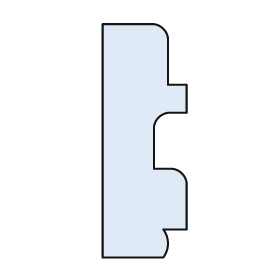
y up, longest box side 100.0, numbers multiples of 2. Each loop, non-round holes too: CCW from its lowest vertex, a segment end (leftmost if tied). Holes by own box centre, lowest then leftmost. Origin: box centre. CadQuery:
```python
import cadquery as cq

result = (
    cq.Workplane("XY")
    .moveTo(-18.0, -50.0)
    .lineTo(8.0, -50.0)
    .threePointArc((10.0, -44.0), (8.0, -38.0))
    .lineTo(18.0, -38.0)
    .lineTo(18.0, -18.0)
    .threePointArc((16.0, -14.0), (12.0, -12.0))
    .lineTo(4.0, -12.0)
    .lineTo(4.0, 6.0)
    .threePointArc((6.0, 10.0), (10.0, 12.0))
    .lineTo(18.0, 12.0)
    .lineTo(18.0, 24.0)
    .lineTo(10.0, 24.0)
    .lineTo(10.0, 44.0)
    .threePointArc((8.0, 48.0), (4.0, 50.0))
    .lineTo(-18.0, 50.0)
    .close()
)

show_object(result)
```